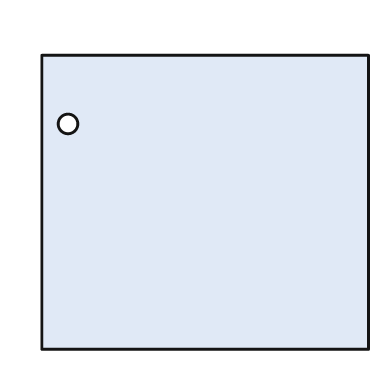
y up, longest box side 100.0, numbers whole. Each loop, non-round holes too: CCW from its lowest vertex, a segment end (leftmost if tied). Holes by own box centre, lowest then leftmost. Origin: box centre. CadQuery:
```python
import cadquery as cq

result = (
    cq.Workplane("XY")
    .moveTo(-50.0, -45.0)
    .lineTo(50.0, -45.0)
    .lineTo(50.0, 45.0)
    .lineTo(-50.0, 45.0)
    .close()
    .moveTo(-42.0, 24.0)
    .circle(3.0)
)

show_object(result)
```